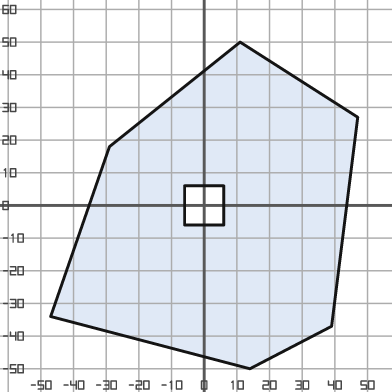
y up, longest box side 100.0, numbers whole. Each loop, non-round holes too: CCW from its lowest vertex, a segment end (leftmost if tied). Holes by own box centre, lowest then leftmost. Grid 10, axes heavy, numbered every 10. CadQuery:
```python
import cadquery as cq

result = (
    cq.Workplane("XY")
    .moveTo(14.0, -50.0)
    .lineTo(39.0, -37.0)
    .lineTo(47.0, 27.0)
    .lineTo(11.0, 50.0)
    .lineTo(-29.0, 18.0)
    .lineTo(-47.0, -34.0)
    .close()
    .moveTo(-6.0, -6.0)
    .lineTo(6.0, -6.0)
    .lineTo(6.0, 6.0)
    .lineTo(-6.0, 6.0)
    .close()
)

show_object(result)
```